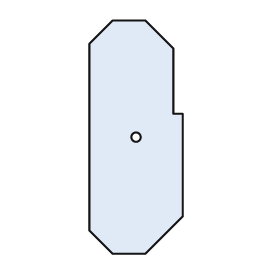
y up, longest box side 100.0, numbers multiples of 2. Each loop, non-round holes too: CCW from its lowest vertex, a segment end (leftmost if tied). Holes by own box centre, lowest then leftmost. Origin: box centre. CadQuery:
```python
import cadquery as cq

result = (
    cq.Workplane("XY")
    .moveTo(-10.0, -50.0)
    .lineTo(4.0, -50.0)
    .lineTo(20.0, -34.0)
    .lineTo(20.0, 10.0)
    .lineTo(16.0, 10.0)
    .lineTo(16.0, 38.0)
    .lineTo(4.0, 50.0)
    .lineTo(-10.0, 50.0)
    .lineTo(-20.0, 40.0)
    .lineTo(-20.0, -40.0)
    .close()
    .moveTo(0.0, 0.0)
    .circle(2.0)
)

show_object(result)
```